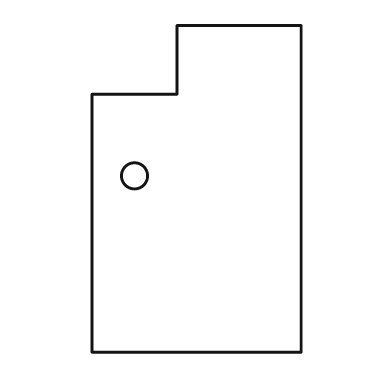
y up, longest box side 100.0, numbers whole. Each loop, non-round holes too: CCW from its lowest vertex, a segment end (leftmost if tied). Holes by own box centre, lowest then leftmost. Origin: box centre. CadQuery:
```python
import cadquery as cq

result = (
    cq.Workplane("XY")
    .moveTo(-32.0, -50.0)
    .lineTo(32.0, -50.0)
    .lineTo(32.0, 50.0)
    .lineTo(-6.0, 50.0)
    .lineTo(-6.0, 29.0)
    .lineTo(-32.0, 29.0)
    .close()
    .moveTo(-19.0, 4.0)
    .circle(4.0)
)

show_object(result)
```